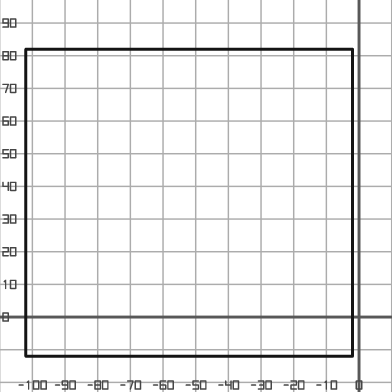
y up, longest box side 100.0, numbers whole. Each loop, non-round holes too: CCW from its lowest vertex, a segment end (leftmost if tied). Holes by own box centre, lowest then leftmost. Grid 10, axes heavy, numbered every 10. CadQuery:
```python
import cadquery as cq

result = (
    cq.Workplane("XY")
    .moveTo(-102.0, -12.0)
    .lineTo(-2.0, -12.0)
    .lineTo(-2.0, 82.0)
    .lineTo(-102.0, 82.0)
    .close()
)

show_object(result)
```